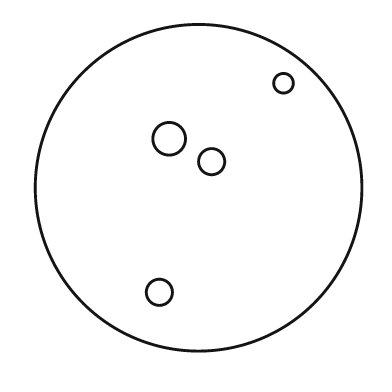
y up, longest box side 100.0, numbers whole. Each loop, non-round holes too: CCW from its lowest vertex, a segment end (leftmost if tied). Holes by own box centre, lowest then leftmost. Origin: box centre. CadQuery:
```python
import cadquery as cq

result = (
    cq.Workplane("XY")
    .moveTo(0.0, 0.0)
    .circle(50.0)
    .moveTo(-12.0, -32.0)
    .circle(4.0)
    .moveTo(4.0, 8.0)
    .circle(4.0)
    .moveTo(-9.0, 15.0)
    .circle(5.0)
    .moveTo(26.0, 32.0)
    .circle(3.0)
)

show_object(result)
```